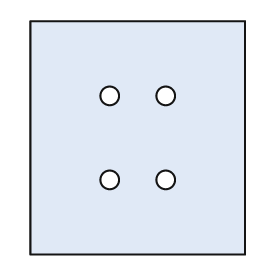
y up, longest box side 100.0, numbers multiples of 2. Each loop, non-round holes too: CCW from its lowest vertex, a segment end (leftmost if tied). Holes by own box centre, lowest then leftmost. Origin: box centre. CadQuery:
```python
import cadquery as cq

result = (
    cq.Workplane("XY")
    .moveTo(-46.0, -50.0)
    .lineTo(46.0, -50.0)
    .lineTo(46.0, 50.0)
    .lineTo(-46.0, 50.0)
    .close()
    .moveTo(-12.0, -18.0)
    .circle(4.0)
    .moveTo(12.0, -18.0)
    .circle(4.0)
    .moveTo(-12.0, 18.0)
    .circle(4.0)
    .moveTo(12.0, 18.0)
    .circle(4.0)
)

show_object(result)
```